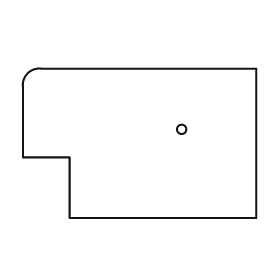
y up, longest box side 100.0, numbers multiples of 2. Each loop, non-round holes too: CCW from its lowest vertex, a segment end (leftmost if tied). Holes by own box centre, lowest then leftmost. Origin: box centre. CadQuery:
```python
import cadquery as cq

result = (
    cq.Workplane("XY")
    .moveTo(-30.0, -32.0)
    .lineTo(50.0, -32.0)
    .lineTo(50.0, 32.0)
    .lineTo(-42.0, 32.0)
    .threePointArc((-48.0, 30.0), (-50.0, 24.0))
    .lineTo(-50.0, -6.0)
    .lineTo(-30.0, -6.0)
    .close()
    .moveTo(18.0, 6.0)
    .circle(2.0)
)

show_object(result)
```